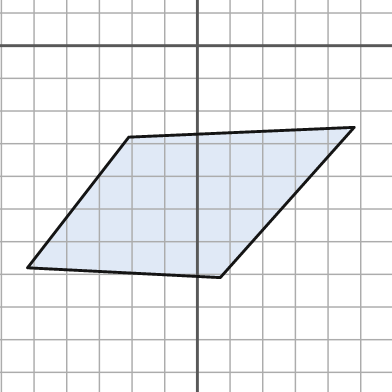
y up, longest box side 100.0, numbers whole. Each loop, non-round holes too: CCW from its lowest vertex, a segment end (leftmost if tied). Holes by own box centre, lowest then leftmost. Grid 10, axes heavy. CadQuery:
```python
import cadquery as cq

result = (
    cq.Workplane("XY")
    .moveTo(7.0, -71.0)
    .lineTo(48.0, -25.0)
    .lineTo(-21.0, -28.0)
    .lineTo(-52.0, -68.0)
    .close()
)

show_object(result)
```